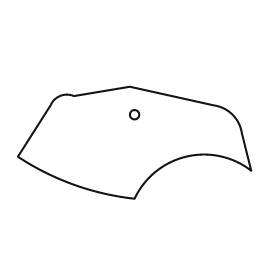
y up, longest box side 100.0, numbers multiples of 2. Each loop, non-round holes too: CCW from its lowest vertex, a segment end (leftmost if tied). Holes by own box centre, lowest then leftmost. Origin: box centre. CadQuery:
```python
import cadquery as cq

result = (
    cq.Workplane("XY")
    .moveTo(0.0, -24.0)
    .threePointArc((22.0, -6.0), (50.0, -12.0))
    .lineTo(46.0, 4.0)
    .threePointArc((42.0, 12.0), (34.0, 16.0))
    .lineTo(-2.0, 24.0)
    .lineTo(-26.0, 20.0)
    .threePointArc((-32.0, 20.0), (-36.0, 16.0))
    .lineTo(-50.0, -6.0)
    .threePointArc((-26.0, -18.0), (0.0, -24.0))
    .close()
    .moveTo(0.0, 12.0)
    .circle(2.0)
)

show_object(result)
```